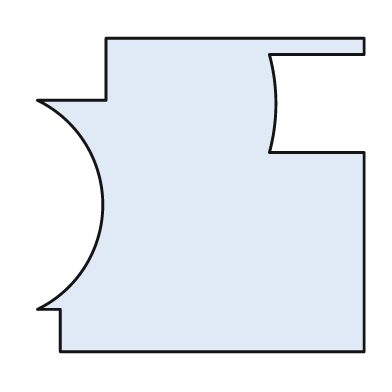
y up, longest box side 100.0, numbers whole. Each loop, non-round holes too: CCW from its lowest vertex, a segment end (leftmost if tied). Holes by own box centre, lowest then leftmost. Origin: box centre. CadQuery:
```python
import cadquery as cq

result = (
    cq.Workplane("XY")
    .moveTo(-43.0, -48.0)
    .lineTo(50.0, -48.0)
    .lineTo(50.0, 13.0)
    .lineTo(21.0, 13.0)
    .threePointArc((23.0, 28.0), (21.0, 43.0))
    .lineTo(50.0, 43.0)
    .lineTo(50.0, 48.0)
    .lineTo(-29.0, 48.0)
    .lineTo(-29.0, 29.0)
    .lineTo(-50.0, 29.0)
    .threePointArc((-30.0, -3.0), (-50.0, -35.0))
    .lineTo(-43.0, -35.0)
    .close()
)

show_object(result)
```